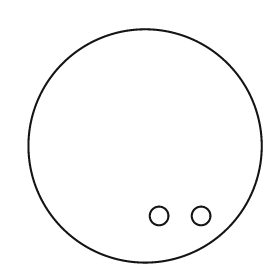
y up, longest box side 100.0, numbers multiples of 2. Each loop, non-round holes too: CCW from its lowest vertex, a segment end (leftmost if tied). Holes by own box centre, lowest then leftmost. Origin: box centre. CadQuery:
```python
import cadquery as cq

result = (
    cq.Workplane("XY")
    .moveTo(0.0, 0.0)
    .circle(50.0)
    .moveTo(6.0, -30.0)
    .circle(4.0)
    .moveTo(24.0, -30.0)
    .circle(4.0)
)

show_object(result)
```